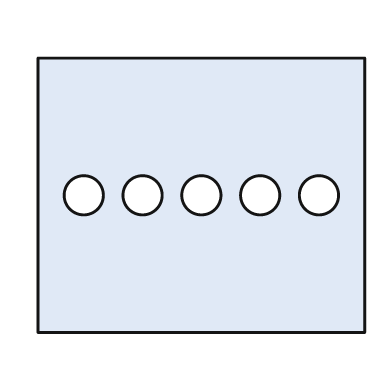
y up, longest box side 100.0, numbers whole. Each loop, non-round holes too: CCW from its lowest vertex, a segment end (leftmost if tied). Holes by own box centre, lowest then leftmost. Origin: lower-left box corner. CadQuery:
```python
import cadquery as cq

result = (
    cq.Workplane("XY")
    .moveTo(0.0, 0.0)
    .lineTo(100.0, 0.0)
    .lineTo(100.0, 84.0)
    .lineTo(0.0, 84.0)
    .close()
    .moveTo(14.0, 42.0)
    .circle(6.0)
    .moveTo(32.0, 42.0)
    .circle(6.0)
    .moveTo(50.0, 42.0)
    .circle(6.0)
    .moveTo(68.0, 42.0)
    .circle(6.0)
    .moveTo(86.0, 42.0)
    .circle(6.0)
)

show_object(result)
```